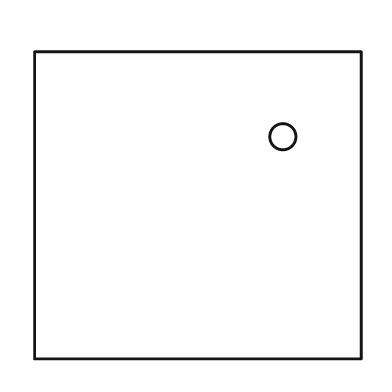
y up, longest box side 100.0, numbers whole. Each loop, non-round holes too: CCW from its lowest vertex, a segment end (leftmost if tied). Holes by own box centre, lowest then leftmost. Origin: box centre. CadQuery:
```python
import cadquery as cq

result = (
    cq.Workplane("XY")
    .moveTo(-50.0, -47.0)
    .lineTo(50.0, -47.0)
    .lineTo(50.0, 47.0)
    .lineTo(-50.0, 47.0)
    .close()
    .moveTo(26.0, 21.0)
    .circle(4.0)
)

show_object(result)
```